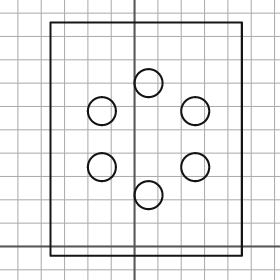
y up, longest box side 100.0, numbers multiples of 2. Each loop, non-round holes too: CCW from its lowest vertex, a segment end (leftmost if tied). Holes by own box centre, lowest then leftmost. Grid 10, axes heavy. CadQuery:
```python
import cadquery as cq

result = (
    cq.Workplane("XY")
    .moveTo(-36.0, -4.0)
    .lineTo(46.0, -4.0)
    .lineTo(46.0, 96.0)
    .lineTo(-36.0, 96.0)
    .close()
    .moveTo(6.0, 22.0)
    .circle(6.0)
    .moveTo(-14.0, 34.0)
    .circle(6.0)
    .moveTo(26.0, 34.0)
    .circle(6.0)
    .moveTo(-14.0, 58.0)
    .circle(6.0)
    .moveTo(26.0, 58.0)
    .circle(6.0)
    .moveTo(6.0, 70.0)
    .circle(6.0)
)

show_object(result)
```